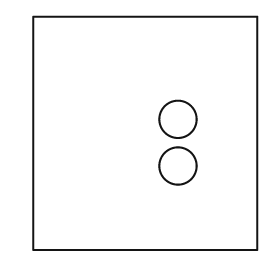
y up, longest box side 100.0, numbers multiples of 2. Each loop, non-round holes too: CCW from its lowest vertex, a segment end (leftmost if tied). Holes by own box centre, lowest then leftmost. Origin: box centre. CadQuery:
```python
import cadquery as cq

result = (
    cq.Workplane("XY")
    .moveTo(-48.0, -50.0)
    .lineTo(48.0, -50.0)
    .lineTo(48.0, 50.0)
    .lineTo(-48.0, 50.0)
    .close()
    .moveTo(14.0, -14.0)
    .circle(8.0)
    .moveTo(14.0, 6.0)
    .circle(8.0)
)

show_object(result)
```